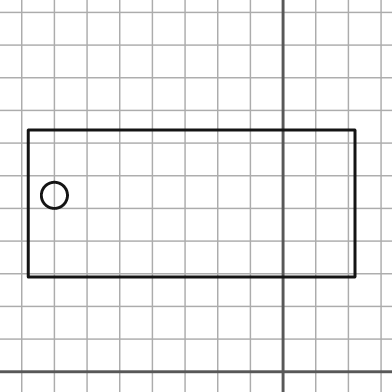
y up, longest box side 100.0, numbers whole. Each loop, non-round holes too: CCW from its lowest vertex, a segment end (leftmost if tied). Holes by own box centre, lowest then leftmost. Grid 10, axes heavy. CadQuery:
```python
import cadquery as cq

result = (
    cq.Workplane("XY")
    .moveTo(-78.0, 29.0)
    .lineTo(22.0, 29.0)
    .lineTo(22.0, 74.0)
    .lineTo(-78.0, 74.0)
    .close()
    .moveTo(-70.0, 54.0)
    .circle(4.0)
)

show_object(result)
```